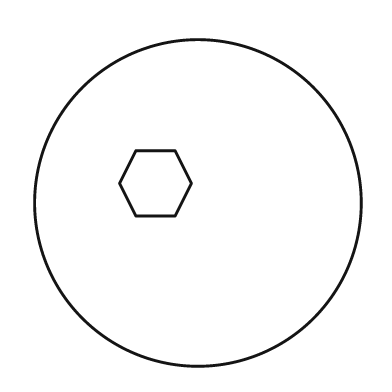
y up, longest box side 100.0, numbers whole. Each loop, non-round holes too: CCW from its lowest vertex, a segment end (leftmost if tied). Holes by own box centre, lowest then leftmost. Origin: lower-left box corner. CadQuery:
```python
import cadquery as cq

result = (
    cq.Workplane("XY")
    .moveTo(50.0, 50.0)
    .circle(50.0)
    .moveTo(31.0, 46.0)
    .lineTo(43.0, 46.0)
    .lineTo(48.0, 56.0)
    .lineTo(43.0, 66.0)
    .lineTo(31.0, 66.0)
    .lineTo(26.0, 56.0)
    .close()
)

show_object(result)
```